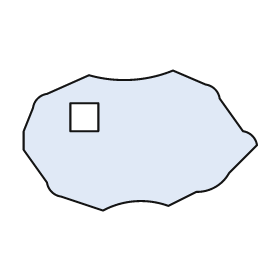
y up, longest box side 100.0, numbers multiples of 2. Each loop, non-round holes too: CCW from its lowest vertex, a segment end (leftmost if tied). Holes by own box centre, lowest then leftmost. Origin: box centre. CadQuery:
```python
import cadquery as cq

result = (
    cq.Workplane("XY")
    .moveTo(-16.0, -30.0)
    .threePointArc((-2.0, -26.0), (12.0, -28.0))
    .lineTo(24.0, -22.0)
    .threePointArc((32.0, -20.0), (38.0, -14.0))
    .lineTo(50.0, -2.0)
    .threePointArc((48.0, 2.0), (44.0, 4.0))
    .lineTo(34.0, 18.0)
    .threePointArc((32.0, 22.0), (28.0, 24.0))
    .lineTo(14.0, 30.0)
    .threePointArc((-4.0, 26.0), (-22.0, 28.0))
    .lineTo(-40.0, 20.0)
    .threePointArc((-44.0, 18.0), (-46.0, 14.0))
    .lineTo(-50.0, 4.0)
    .lineTo(-50.0, -4.0)
    .lineTo(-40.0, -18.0)
    .threePointArc((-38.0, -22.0), (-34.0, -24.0))
    .close()
    .moveTo(-30.0, 4.0)
    .lineTo(-18.0, 4.0)
    .lineTo(-18.0, 16.0)
    .lineTo(-30.0, 16.0)
    .close()
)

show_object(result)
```